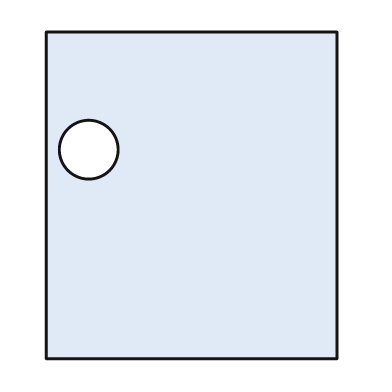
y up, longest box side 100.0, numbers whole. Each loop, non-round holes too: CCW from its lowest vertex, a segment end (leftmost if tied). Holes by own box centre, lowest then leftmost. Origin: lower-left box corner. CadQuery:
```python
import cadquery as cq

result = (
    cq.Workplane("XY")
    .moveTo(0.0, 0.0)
    .lineTo(89.0, 0.0)
    .lineTo(89.0, 100.0)
    .lineTo(0.0, 100.0)
    .close()
    .moveTo(13.0, 64.0)
    .circle(9.0)
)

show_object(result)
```